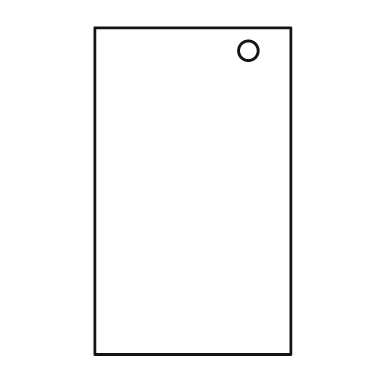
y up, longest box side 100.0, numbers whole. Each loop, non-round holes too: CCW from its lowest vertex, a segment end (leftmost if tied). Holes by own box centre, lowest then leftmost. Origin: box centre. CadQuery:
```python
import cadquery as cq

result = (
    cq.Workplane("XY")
    .moveTo(-30.0, -50.0)
    .lineTo(30.0, -50.0)
    .lineTo(30.0, 50.0)
    .lineTo(-30.0, 50.0)
    .close()
    .moveTo(17.0, 43.0)
    .circle(3.0)
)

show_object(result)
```